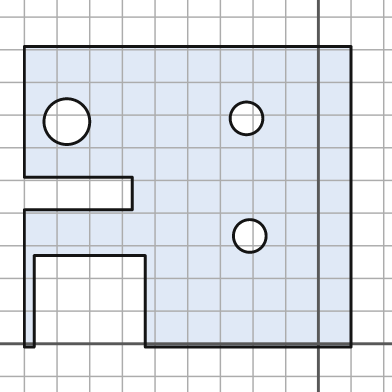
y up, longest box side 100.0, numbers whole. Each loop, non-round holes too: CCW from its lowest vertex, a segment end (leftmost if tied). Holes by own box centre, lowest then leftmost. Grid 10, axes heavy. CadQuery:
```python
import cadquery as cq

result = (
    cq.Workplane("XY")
    .moveTo(-90.0, -1.0)
    .lineTo(-87.0, -1.0)
    .lineTo(-87.0, 27.0)
    .lineTo(-53.0, 27.0)
    .lineTo(-53.0, -1.0)
    .lineTo(10.0, -1.0)
    .lineTo(10.0, 91.0)
    .lineTo(-90.0, 91.0)
    .lineTo(-90.0, 51.0)
    .lineTo(-57.0, 51.0)
    .lineTo(-57.0, 41.0)
    .lineTo(-90.0, 41.0)
    .close()
    .moveTo(-21.0, 33.0)
    .circle(5.0)
    .moveTo(-77.0, 68.0)
    .circle(7.0)
    .moveTo(-22.0, 69.0)
    .circle(5.0)
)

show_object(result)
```